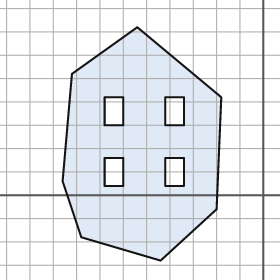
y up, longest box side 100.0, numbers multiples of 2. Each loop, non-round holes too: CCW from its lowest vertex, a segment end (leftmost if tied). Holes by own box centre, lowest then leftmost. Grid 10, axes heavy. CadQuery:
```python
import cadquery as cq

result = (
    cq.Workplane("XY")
    .moveTo(-44.0, -28.0)
    .lineTo(-20.0, -6.0)
    .lineTo(-18.0, 42.0)
    .lineTo(-54.0, 72.0)
    .lineTo(-82.0, 52.0)
    .lineTo(-86.0, 6.0)
    .lineTo(-78.0, -18.0)
    .close()
    .moveTo(-68.0, 4.0)
    .lineTo(-60.0, 4.0)
    .lineTo(-60.0, 16.0)
    .lineTo(-68.0, 16.0)
    .close()
    .moveTo(-42.0, 4.0)
    .lineTo(-34.0, 4.0)
    .lineTo(-34.0, 16.0)
    .lineTo(-42.0, 16.0)
    .close()
    .moveTo(-68.0, 30.0)
    .lineTo(-60.0, 30.0)
    .lineTo(-60.0, 42.0)
    .lineTo(-68.0, 42.0)
    .close()
    .moveTo(-42.0, 30.0)
    .lineTo(-34.0, 30.0)
    .lineTo(-34.0, 42.0)
    .lineTo(-42.0, 42.0)
    .close()
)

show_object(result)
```